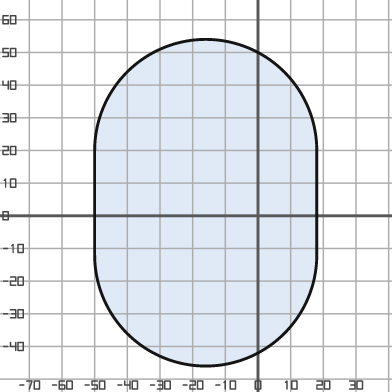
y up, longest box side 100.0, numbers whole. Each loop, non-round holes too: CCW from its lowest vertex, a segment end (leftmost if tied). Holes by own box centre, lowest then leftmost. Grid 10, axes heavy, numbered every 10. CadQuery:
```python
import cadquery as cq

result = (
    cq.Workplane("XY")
    .moveTo(-50.0, -12.0)
    .threePointArc((-16.0, -46.0), (18.0, -12.0))
    .lineTo(18.0, 20.0)
    .threePointArc((-16.0, 54.0), (-50.0, 20.0))
    .close()
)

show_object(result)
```